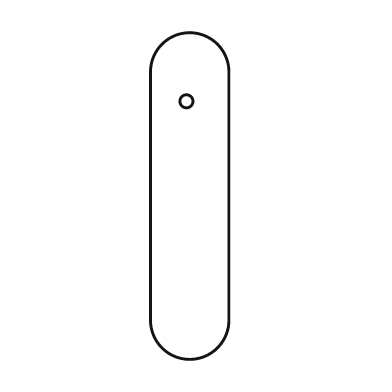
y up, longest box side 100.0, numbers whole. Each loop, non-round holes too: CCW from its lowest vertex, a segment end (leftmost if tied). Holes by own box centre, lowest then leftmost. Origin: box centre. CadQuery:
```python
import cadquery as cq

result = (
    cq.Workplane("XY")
    .moveTo(-12.0, -38.0)
    .threePointArc((0.0, -50.0), (12.0, -38.0))
    .lineTo(12.0, 38.0)
    .threePointArc((0.0, 50.0), (-12.0, 38.0))
    .close()
    .moveTo(-1.0, 29.0)
    .circle(2.0)
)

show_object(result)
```